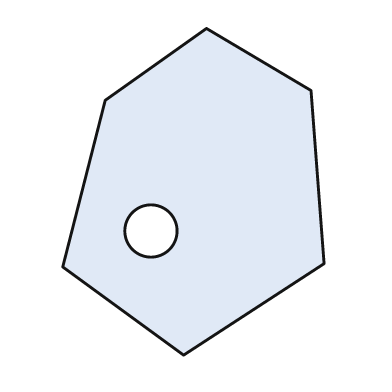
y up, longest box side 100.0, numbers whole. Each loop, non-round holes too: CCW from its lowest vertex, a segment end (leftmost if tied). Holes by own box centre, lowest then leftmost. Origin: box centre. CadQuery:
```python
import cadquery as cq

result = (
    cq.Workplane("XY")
    .moveTo(-3.0, -50.0)
    .lineTo(40.0, -22.0)
    .lineTo(36.0, 31.0)
    .lineTo(4.0, 50.0)
    .lineTo(-27.0, 28.0)
    .lineTo(-40.0, -23.0)
    .close()
    .moveTo(-13.0, -12.0)
    .circle(8.0)
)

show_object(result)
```